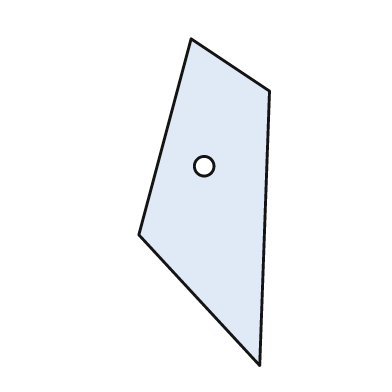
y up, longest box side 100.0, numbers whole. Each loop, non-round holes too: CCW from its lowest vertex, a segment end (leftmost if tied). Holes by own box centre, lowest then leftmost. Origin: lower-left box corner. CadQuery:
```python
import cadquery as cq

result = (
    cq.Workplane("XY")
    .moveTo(37.0, 0.0)
    .lineTo(40.0, 84.0)
    .lineTo(16.0, 100.0)
    .lineTo(0.0, 40.0)
    .close()
    .moveTo(20.0, 61.0)
    .circle(3.0)
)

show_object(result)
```